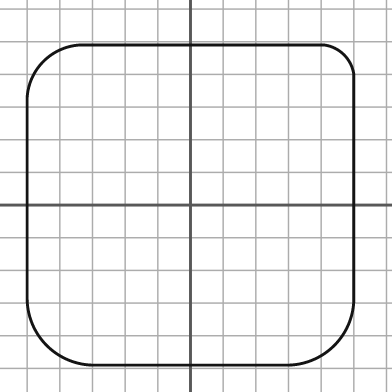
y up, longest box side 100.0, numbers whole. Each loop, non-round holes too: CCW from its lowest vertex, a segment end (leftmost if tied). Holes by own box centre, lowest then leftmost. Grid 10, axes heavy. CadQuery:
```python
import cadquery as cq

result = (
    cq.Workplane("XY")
    .moveTo(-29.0, -49.0)
    .lineTo(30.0, -49.0)
    .threePointArc((44.0, -43.0), (50.0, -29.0))
    .lineTo(50.0, 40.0)
    .threePointArc((47.0, 46.0), (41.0, 49.0))
    .lineTo(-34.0, 49.0)
    .threePointArc((-45.0, 44.0), (-50.0, 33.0))
    .lineTo(-50.0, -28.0)
    .threePointArc((-44.0, -43.0), (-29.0, -49.0))
    .close()
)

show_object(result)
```